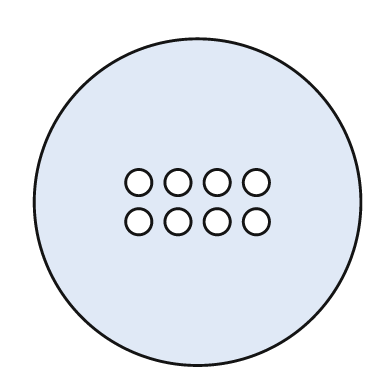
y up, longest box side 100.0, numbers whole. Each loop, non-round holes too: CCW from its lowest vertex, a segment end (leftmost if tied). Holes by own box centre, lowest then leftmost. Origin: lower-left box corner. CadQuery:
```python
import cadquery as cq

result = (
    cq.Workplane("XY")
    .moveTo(50.0, 50.0)
    .circle(50.0)
    .moveTo(32.0, 44.0)
    .circle(4.0)
    .moveTo(44.0, 44.0)
    .circle(4.0)
    .moveTo(56.0, 44.0)
    .circle(4.0)
    .moveTo(68.0, 44.0)
    .circle(4.0)
    .moveTo(32.0, 56.0)
    .circle(4.0)
    .moveTo(44.0, 56.0)
    .circle(4.0)
    .moveTo(56.0, 56.0)
    .circle(4.0)
    .moveTo(68.0, 56.0)
    .circle(4.0)
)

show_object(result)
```